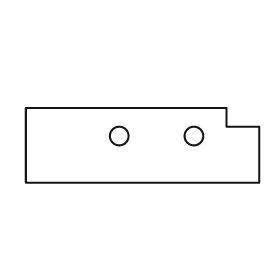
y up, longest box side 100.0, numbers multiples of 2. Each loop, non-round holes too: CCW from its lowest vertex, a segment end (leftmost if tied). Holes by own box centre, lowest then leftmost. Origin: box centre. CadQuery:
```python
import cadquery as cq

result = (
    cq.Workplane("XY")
    .moveTo(-50.0, -16.0)
    .lineTo(50.0, -16.0)
    .lineTo(50.0, 8.0)
    .lineTo(36.0, 8.0)
    .lineTo(36.0, 16.0)
    .lineTo(-50.0, 16.0)
    .close()
    .moveTo(-10.0, 4.0)
    .circle(4.0)
    .moveTo(22.0, 4.0)
    .circle(4.0)
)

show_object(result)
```